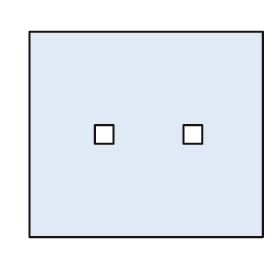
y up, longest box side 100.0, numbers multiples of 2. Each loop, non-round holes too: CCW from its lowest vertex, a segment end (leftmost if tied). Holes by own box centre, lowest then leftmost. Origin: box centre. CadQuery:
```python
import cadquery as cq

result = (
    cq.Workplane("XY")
    .moveTo(-50.0, -44.0)
    .lineTo(50.0, -44.0)
    .lineTo(50.0, 44.0)
    .lineTo(-50.0, 44.0)
    .close()
    .moveTo(-22.0, -4.0)
    .lineTo(-14.0, -4.0)
    .lineTo(-14.0, 4.0)
    .lineTo(-22.0, 4.0)
    .close()
    .moveTo(16.0, -4.0)
    .lineTo(24.0, -4.0)
    .lineTo(24.0, 4.0)
    .lineTo(16.0, 4.0)
    .close()
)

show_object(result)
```